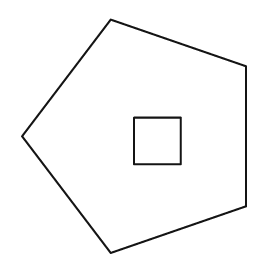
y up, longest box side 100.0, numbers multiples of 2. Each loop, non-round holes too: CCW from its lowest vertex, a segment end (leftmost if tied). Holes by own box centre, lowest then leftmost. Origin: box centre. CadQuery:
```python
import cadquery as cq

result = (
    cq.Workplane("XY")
    .moveTo(-10.0, -50.0)
    .lineTo(48.0, -30.0)
    .lineTo(48.0, 30.0)
    .lineTo(-10.0, 50.0)
    .lineTo(-48.0, 0.0)
    .close()
    .moveTo(0.0, -12.0)
    .lineTo(20.0, -12.0)
    .lineTo(20.0, 8.0)
    .lineTo(0.0, 8.0)
    .close()
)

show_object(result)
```